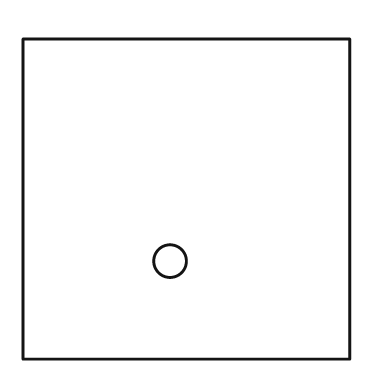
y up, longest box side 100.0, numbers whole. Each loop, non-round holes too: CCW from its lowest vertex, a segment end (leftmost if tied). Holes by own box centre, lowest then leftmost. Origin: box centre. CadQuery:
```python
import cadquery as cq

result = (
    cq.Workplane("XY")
    .moveTo(-50.0, -49.0)
    .lineTo(50.0, -49.0)
    .lineTo(50.0, 49.0)
    .lineTo(-50.0, 49.0)
    .close()
    .moveTo(-5.0, -19.0)
    .circle(5.0)
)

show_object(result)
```